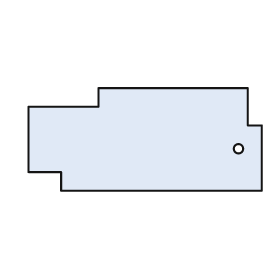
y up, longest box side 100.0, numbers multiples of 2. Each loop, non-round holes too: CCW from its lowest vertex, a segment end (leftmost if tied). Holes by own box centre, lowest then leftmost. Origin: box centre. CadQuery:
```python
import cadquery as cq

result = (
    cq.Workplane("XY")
    .moveTo(-36.0, -22.0)
    .lineTo(50.0, -22.0)
    .lineTo(50.0, 6.0)
    .lineTo(44.0, 6.0)
    .lineTo(44.0, 22.0)
    .lineTo(-20.0, 22.0)
    .lineTo(-20.0, 14.0)
    .lineTo(-50.0, 14.0)
    .lineTo(-50.0, -14.0)
    .lineTo(-36.0, -14.0)
    .close()
    .moveTo(40.0, -4.0)
    .circle(2.0)
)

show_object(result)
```